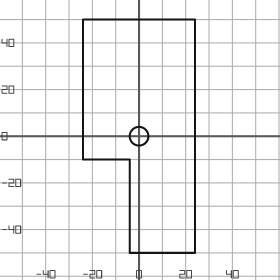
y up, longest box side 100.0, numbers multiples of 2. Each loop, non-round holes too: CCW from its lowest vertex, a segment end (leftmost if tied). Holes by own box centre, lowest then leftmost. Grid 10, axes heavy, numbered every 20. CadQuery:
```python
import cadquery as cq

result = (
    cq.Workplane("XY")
    .moveTo(-4.0, -50.0)
    .lineTo(24.0, -50.0)
    .lineTo(24.0, 50.0)
    .lineTo(-24.0, 50.0)
    .lineTo(-24.0, -10.0)
    .lineTo(-4.0, -10.0)
    .close()
    .moveTo(0.0, 0.0)
    .circle(4.0)
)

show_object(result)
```